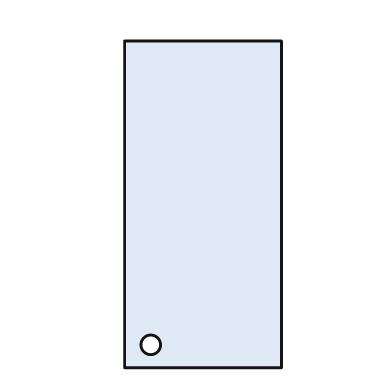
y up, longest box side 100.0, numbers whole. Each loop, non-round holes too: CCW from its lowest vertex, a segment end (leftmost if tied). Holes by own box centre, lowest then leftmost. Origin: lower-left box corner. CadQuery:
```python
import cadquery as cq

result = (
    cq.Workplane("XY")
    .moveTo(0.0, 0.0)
    .lineTo(48.0, 0.0)
    .lineTo(48.0, 100.0)
    .lineTo(0.0, 100.0)
    .close()
    .moveTo(8.0, 7.0)
    .circle(3.0)
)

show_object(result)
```